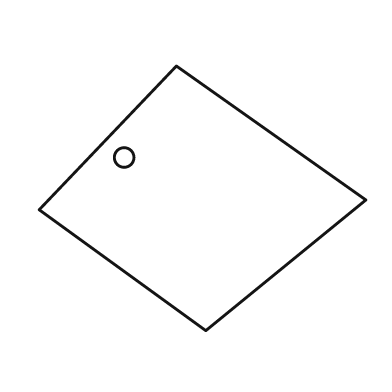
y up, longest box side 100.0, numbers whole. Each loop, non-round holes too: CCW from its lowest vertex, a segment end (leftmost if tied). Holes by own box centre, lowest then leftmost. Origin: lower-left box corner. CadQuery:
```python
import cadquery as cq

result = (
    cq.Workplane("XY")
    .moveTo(51.0, 0.0)
    .lineTo(100.0, 40.0)
    .lineTo(42.0, 81.0)
    .lineTo(0.0, 37.0)
    .close()
    .moveTo(26.0, 53.0)
    .circle(3.0)
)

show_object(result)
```